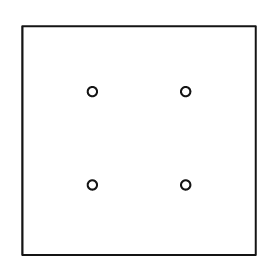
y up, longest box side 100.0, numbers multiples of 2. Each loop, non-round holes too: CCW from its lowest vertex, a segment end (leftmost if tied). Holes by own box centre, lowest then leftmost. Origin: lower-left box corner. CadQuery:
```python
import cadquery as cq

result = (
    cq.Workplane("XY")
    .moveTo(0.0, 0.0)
    .lineTo(100.0, 0.0)
    .lineTo(100.0, 98.0)
    .lineTo(0.0, 98.0)
    .close()
    .moveTo(30.0, 30.0)
    .circle(2.0)
    .moveTo(70.0, 30.0)
    .circle(2.0)
    .moveTo(30.0, 70.0)
    .circle(2.0)
    .moveTo(70.0, 70.0)
    .circle(2.0)
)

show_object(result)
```